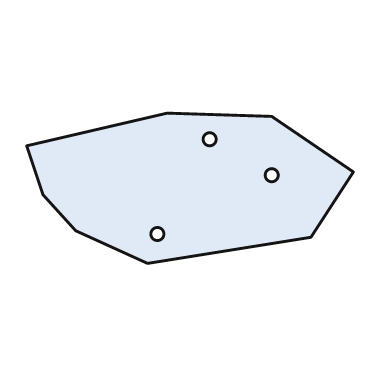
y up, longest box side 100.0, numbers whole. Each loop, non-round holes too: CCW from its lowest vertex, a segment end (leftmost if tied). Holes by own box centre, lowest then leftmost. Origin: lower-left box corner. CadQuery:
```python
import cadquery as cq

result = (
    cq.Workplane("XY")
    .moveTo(37.0, 0.0)
    .lineTo(87.0, 8.0)
    .lineTo(100.0, 28.0)
    .lineTo(75.0, 45.0)
    .lineTo(43.0, 46.0)
    .lineTo(0.0, 36.0)
    .lineTo(5.0, 21.0)
    .lineTo(15.0, 10.0)
    .close()
    .moveTo(40.0, 9.0)
    .circle(2.0)
    .moveTo(75.0, 27.0)
    .circle(2.0)
    .moveTo(56.0, 38.0)
    .circle(2.0)
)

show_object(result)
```